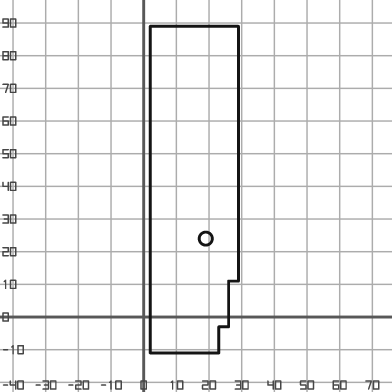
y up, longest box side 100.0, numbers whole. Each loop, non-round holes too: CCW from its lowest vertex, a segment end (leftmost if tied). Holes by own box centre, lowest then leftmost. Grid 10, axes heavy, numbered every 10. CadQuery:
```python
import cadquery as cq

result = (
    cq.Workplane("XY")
    .moveTo(2.0, -11.0)
    .lineTo(23.0, -11.0)
    .lineTo(23.0, -3.0)
    .lineTo(26.0, -3.0)
    .lineTo(26.0, 11.0)
    .lineTo(29.0, 11.0)
    .lineTo(29.0, 89.0)
    .lineTo(2.0, 89.0)
    .close()
    .moveTo(19.0, 24.0)
    .circle(2.0)
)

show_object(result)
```